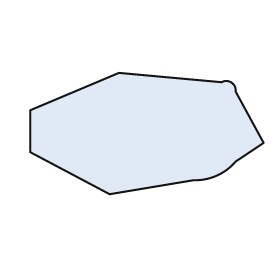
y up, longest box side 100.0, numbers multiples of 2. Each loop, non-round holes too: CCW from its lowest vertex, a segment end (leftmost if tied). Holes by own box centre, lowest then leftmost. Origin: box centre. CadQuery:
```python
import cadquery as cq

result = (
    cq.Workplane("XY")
    .moveTo(-16.0, -26.0)
    .lineTo(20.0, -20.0)
    .threePointArc((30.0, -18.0), (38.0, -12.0))
    .lineTo(50.0, -4.0)
    .lineTo(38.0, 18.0)
    .threePointArc((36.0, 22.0), (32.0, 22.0))
    .lineTo(-12.0, 26.0)
    .lineTo(-50.0, 10.0)
    .lineTo(-50.0, -8.0)
    .close()
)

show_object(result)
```